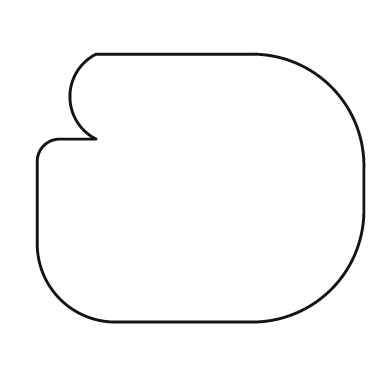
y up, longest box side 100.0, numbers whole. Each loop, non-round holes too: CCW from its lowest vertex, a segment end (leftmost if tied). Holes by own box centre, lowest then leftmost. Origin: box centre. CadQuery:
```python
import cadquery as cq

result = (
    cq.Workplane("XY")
    .moveTo(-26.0, -41.0)
    .lineTo(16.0, -41.0)
    .threePointArc((40.0, -31.0), (50.0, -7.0))
    .lineTo(50.0, 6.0)
    .threePointArc((40.0, 31.0), (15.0, 41.0))
    .lineTo(-32.0, 41.0)
    .threePointArc((-40.0, 28.0), (-32.0, 15.0))
    .lineTo(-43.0, 15.0)
    .threePointArc((-48.0, 13.0), (-50.0, 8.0))
    .lineTo(-50.0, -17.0)
    .threePointArc((-43.0, -34.0), (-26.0, -41.0))
    .close()
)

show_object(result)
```